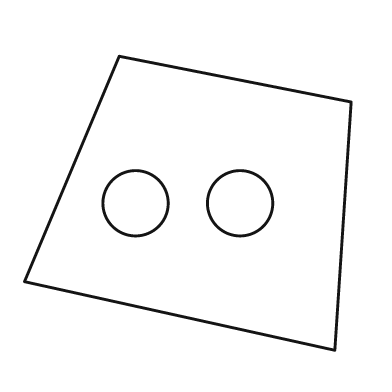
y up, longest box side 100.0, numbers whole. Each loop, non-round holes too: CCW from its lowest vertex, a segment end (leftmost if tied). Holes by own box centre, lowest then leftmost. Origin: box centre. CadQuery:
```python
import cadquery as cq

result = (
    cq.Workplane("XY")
    .moveTo(45.0, -45.0)
    .lineTo(50.0, 31.0)
    .lineTo(-21.0, 45.0)
    .lineTo(-50.0, -24.0)
    .close()
    .moveTo(-16.0, 0.0)
    .circle(10.0)
    .moveTo(16.0, 0.0)
    .circle(10.0)
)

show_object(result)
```